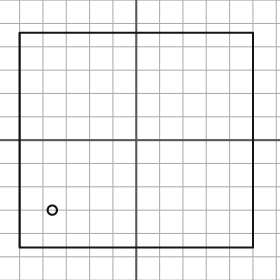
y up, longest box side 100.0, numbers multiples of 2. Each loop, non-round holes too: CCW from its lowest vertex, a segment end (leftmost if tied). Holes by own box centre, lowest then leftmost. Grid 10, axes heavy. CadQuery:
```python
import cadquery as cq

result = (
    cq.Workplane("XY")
    .moveTo(-50.0, -46.0)
    .lineTo(50.0, -46.0)
    .lineTo(50.0, 46.0)
    .lineTo(-50.0, 46.0)
    .close()
    .moveTo(-36.0, -30.0)
    .circle(2.0)
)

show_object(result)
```